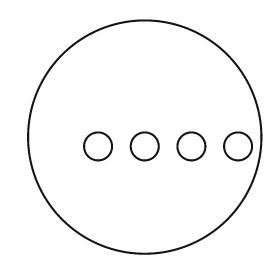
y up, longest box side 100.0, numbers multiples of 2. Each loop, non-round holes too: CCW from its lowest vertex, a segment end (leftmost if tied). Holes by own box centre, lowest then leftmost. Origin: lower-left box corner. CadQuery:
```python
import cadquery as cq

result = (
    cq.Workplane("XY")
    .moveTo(50.0, 50.0)
    .circle(50.0)
    .moveTo(30.0, 46.0)
    .circle(6.0)
    .moveTo(50.0, 46.0)
    .circle(6.0)
    .moveTo(70.0, 46.0)
    .circle(6.0)
    .moveTo(90.0, 46.0)
    .circle(6.0)
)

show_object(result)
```